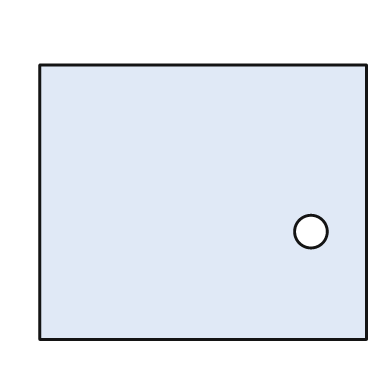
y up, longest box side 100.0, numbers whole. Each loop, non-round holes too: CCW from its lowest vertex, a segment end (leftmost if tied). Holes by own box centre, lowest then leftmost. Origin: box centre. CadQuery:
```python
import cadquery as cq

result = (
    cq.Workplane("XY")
    .moveTo(-50.0, -42.0)
    .lineTo(50.0, -42.0)
    .lineTo(50.0, 42.0)
    .lineTo(-50.0, 42.0)
    .close()
    .moveTo(33.0, -9.0)
    .circle(5.0)
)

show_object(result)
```